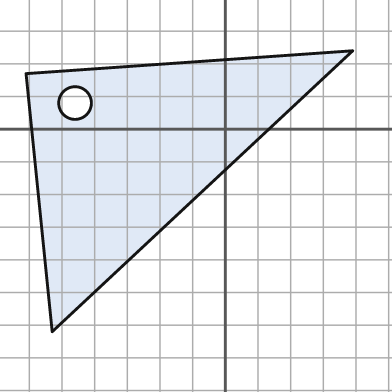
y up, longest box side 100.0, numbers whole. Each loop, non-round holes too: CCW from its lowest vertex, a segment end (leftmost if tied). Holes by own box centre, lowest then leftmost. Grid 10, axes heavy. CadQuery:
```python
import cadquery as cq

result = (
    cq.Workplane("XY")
    .moveTo(-53.0, -62.0)
    .lineTo(39.0, 24.0)
    .lineTo(-61.0, 17.0)
    .close()
    .moveTo(-46.0, 8.0)
    .circle(5.0)
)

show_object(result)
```